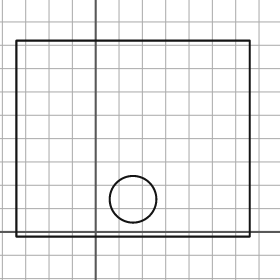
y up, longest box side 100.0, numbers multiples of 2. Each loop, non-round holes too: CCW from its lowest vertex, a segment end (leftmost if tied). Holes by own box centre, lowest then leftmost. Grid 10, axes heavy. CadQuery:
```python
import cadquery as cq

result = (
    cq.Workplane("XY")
    .moveTo(-34.0, -2.0)
    .lineTo(66.0, -2.0)
    .lineTo(66.0, 82.0)
    .lineTo(-34.0, 82.0)
    .close()
    .moveTo(16.0, 14.0)
    .circle(10.0)
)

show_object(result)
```